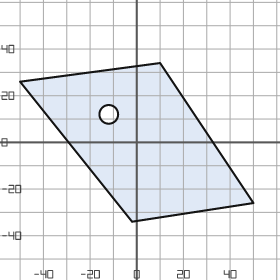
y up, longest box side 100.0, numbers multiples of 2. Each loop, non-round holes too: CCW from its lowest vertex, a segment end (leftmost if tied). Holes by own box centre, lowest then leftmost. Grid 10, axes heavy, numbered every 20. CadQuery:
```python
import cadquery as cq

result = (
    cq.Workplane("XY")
    .moveTo(-2.0, -34.0)
    .lineTo(50.0, -26.0)
    .lineTo(10.0, 34.0)
    .lineTo(-50.0, 26.0)
    .close()
    .moveTo(-12.0, 12.0)
    .circle(4.0)
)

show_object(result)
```